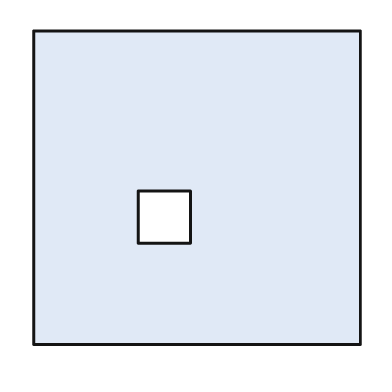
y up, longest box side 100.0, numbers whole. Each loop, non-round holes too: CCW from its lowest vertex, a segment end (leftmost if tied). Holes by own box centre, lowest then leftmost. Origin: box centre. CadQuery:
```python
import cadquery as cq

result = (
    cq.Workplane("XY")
    .moveTo(-50.0, -48.0)
    .lineTo(50.0, -48.0)
    .lineTo(50.0, 48.0)
    .lineTo(-50.0, 48.0)
    .close()
    .moveTo(-18.0, -17.0)
    .lineTo(-2.0, -17.0)
    .lineTo(-2.0, -1.0)
    .lineTo(-18.0, -1.0)
    .close()
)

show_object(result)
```